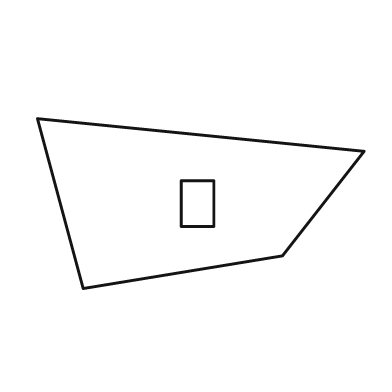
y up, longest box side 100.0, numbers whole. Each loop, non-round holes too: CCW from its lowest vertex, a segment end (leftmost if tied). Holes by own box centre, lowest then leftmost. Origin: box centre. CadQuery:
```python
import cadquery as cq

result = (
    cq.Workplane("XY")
    .moveTo(-36.0, -26.0)
    .lineTo(25.0, -16.0)
    .lineTo(50.0, 16.0)
    .lineTo(-50.0, 26.0)
    .close()
    .moveTo(-6.0, -7.0)
    .lineTo(4.0, -7.0)
    .lineTo(4.0, 7.0)
    .lineTo(-6.0, 7.0)
    .close()
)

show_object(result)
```